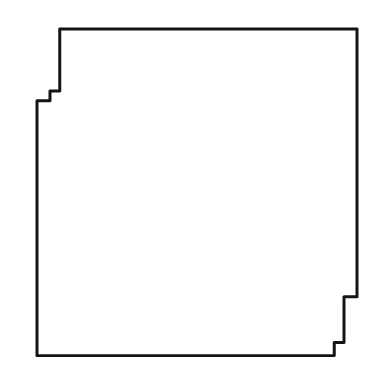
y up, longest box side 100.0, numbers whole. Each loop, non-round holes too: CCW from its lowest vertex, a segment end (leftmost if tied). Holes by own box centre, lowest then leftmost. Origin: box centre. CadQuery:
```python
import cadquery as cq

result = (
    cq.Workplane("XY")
    .moveTo(-49.0, -50.0)
    .lineTo(42.0, -50.0)
    .lineTo(42.0, -46.0)
    .lineTo(45.0, -46.0)
    .lineTo(45.0, -32.0)
    .lineTo(49.0, -32.0)
    .lineTo(49.0, 50.0)
    .lineTo(-42.0, 50.0)
    .lineTo(-42.0, 31.0)
    .lineTo(-45.0, 31.0)
    .lineTo(-45.0, 28.0)
    .lineTo(-49.0, 28.0)
    .close()
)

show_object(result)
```